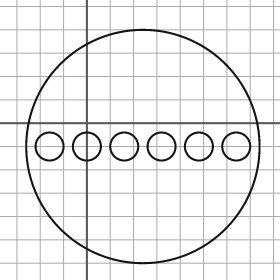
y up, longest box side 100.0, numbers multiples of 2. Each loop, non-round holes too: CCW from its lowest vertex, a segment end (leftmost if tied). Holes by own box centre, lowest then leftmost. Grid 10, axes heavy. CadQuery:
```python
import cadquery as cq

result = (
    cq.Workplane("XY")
    .moveTo(24.0, -10.0)
    .circle(50.0)
    .moveTo(-16.0, -10.0)
    .circle(6.0)
    .moveTo(0.0, -10.0)
    .circle(6.0)
    .moveTo(16.0, -10.0)
    .circle(6.0)
    .moveTo(32.0, -10.0)
    .circle(6.0)
    .moveTo(48.0, -10.0)
    .circle(6.0)
    .moveTo(64.0, -10.0)
    .circle(6.0)
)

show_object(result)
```